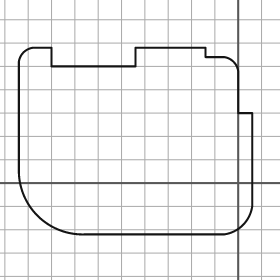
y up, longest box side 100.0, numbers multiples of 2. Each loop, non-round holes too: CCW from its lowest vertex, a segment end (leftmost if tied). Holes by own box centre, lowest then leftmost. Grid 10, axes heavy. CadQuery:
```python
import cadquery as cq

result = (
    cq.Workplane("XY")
    .moveTo(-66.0, -22.0)
    .lineTo(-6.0, -22.0)
    .threePointArc((2.0, -18.0), (6.0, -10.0))
    .lineTo(6.0, 30.0)
    .lineTo(0.0, 30.0)
    .lineTo(0.0, 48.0)
    .threePointArc((-2.0, 52.0), (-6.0, 54.0))
    .lineTo(-14.0, 54.0)
    .lineTo(-14.0, 58.0)
    .lineTo(-44.0, 58.0)
    .lineTo(-44.0, 50.0)
    .lineTo(-80.0, 50.0)
    .lineTo(-80.0, 58.0)
    .lineTo(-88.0, 58.0)
    .threePointArc((-92.0, 56.0), (-94.0, 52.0))
    .lineTo(-94.0, 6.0)
    .threePointArc((-86.0, -14.0), (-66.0, -22.0))
    .close()
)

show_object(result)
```